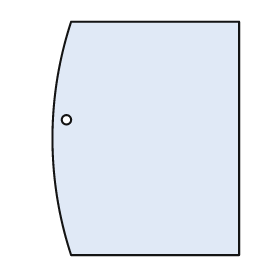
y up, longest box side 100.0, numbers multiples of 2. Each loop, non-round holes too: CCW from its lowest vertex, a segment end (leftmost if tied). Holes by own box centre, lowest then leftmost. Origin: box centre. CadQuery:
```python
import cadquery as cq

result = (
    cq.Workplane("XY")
    .moveTo(-32.0, -50.0)
    .lineTo(40.0, -50.0)
    .lineTo(40.0, 50.0)
    .lineTo(-32.0, 50.0)
    .threePointArc((-40.0, 0.0), (-32.0, -50.0))
    .close()
    .moveTo(-34.0, 8.0)
    .circle(2.0)
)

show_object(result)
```